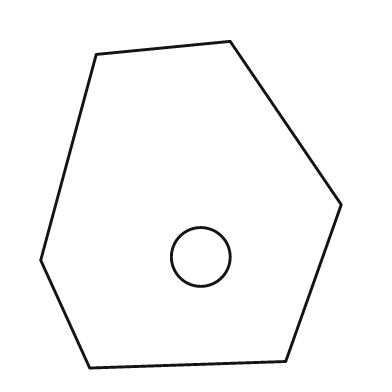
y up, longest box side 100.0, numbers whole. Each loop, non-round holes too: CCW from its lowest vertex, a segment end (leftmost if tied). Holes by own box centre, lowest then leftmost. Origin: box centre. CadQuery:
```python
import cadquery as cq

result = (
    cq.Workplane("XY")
    .moveTo(-31.0, -50.0)
    .lineTo(29.0, -48.0)
    .lineTo(46.0, 0.0)
    .lineTo(12.0, 50.0)
    .lineTo(-29.0, 46.0)
    .lineTo(-46.0, -17.0)
    .close()
    .moveTo(3.0, -16.0)
    .circle(9.0)
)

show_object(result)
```